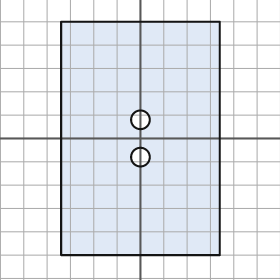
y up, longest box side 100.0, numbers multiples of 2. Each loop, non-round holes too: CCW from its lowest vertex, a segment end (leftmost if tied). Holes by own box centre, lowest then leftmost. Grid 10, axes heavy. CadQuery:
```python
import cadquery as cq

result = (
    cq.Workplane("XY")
    .moveTo(-34.0, -50.0)
    .lineTo(34.0, -50.0)
    .lineTo(34.0, 50.0)
    .lineTo(-34.0, 50.0)
    .close()
    .moveTo(0.0, -8.0)
    .circle(4.0)
    .moveTo(0.0, 8.0)
    .circle(4.0)
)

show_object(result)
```